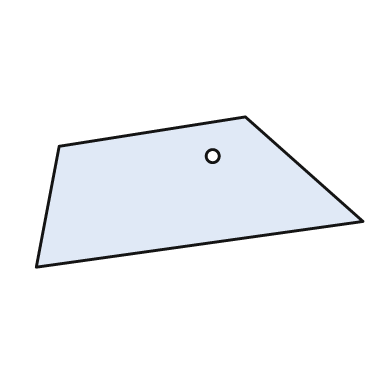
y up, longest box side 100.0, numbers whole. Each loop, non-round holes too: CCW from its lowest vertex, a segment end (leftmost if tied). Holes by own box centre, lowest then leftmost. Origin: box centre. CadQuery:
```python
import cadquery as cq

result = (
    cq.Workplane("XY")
    .moveTo(-50.0, -23.0)
    .lineTo(50.0, -9.0)
    .lineTo(14.0, 23.0)
    .lineTo(-43.0, 14.0)
    .close()
    .moveTo(4.0, 11.0)
    .circle(2.0)
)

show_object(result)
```